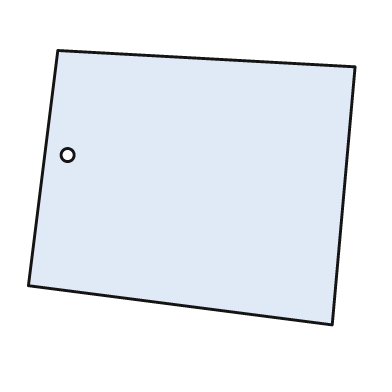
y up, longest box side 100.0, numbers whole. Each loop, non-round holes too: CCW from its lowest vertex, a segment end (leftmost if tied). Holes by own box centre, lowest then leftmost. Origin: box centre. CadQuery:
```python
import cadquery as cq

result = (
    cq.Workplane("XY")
    .moveTo(43.0, -42.0)
    .lineTo(50.0, 37.0)
    .lineTo(-41.0, 42.0)
    .lineTo(-50.0, -30.0)
    .close()
    .moveTo(-38.0, 10.0)
    .circle(2.0)
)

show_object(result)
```